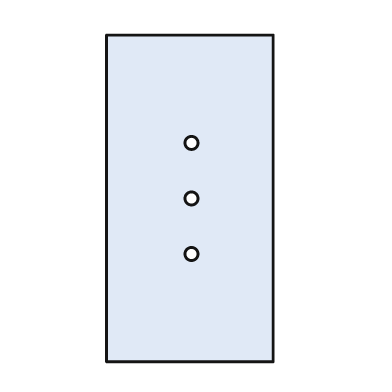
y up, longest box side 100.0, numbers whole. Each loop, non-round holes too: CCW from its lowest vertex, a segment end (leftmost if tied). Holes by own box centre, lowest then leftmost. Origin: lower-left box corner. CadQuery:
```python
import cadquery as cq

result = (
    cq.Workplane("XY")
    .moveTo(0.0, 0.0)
    .lineTo(51.0, 0.0)
    .lineTo(51.0, 100.0)
    .lineTo(0.0, 100.0)
    .close()
    .moveTo(26.0, 33.0)
    .circle(2.0)
    .moveTo(26.0, 50.0)
    .circle(2.0)
    .moveTo(26.0, 67.0)
    .circle(2.0)
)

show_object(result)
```